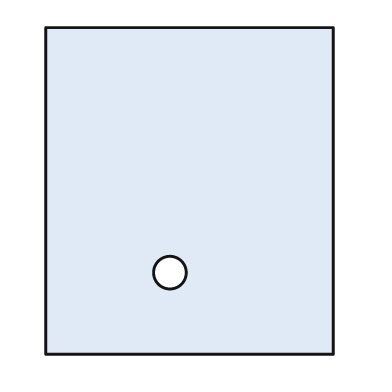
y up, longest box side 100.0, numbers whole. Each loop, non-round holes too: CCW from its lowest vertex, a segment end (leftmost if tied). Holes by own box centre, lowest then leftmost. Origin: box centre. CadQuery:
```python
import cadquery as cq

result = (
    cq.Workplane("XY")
    .moveTo(-44.0, -50.0)
    .lineTo(44.0, -50.0)
    .lineTo(44.0, 50.0)
    .lineTo(-44.0, 50.0)
    .close()
    .moveTo(-6.0, -25.0)
    .circle(5.0)
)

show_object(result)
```